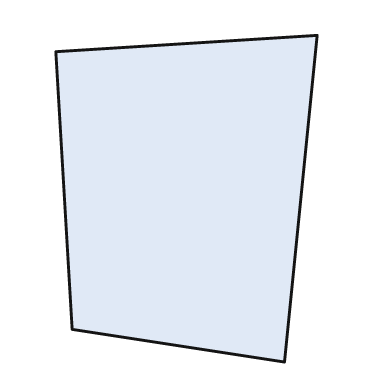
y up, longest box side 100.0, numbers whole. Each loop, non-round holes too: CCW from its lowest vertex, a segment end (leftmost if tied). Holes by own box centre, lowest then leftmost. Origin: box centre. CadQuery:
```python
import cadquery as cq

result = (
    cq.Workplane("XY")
    .moveTo(30.0, -50.0)
    .lineTo(40.0, 50.0)
    .lineTo(-40.0, 45.0)
    .lineTo(-35.0, -40.0)
    .close()
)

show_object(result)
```